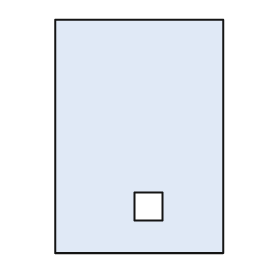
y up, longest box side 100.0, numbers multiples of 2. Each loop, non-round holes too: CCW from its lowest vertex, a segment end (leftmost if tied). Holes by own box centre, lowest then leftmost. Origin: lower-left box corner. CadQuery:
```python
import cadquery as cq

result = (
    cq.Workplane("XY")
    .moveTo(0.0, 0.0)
    .lineTo(72.0, 0.0)
    .lineTo(72.0, 100.0)
    .lineTo(0.0, 100.0)
    .close()
    .moveTo(34.0, 14.0)
    .lineTo(46.0, 14.0)
    .lineTo(46.0, 26.0)
    .lineTo(34.0, 26.0)
    .close()
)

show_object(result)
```